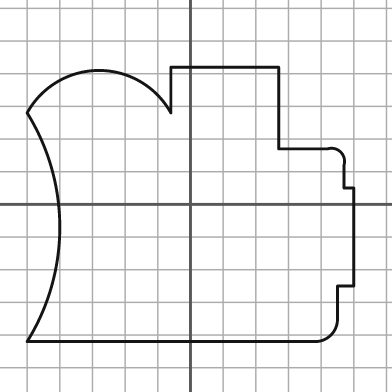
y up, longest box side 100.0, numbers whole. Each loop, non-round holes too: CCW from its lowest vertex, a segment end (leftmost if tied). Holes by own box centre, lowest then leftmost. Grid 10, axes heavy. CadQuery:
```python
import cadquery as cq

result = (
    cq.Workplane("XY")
    .moveTo(-50.0, -42.0)
    .lineTo(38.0, -42.0)
    .threePointArc((43.0, -40.0), (45.0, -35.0))
    .lineTo(45.0, -25.0)
    .lineTo(50.0, -25.0)
    .lineTo(50.0, 5.0)
    .lineTo(47.0, 5.0)
    .lineTo(47.0, 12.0)
    .threePointArc((46.0, 16.0), (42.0, 17.0))
    .lineTo(27.0, 17.0)
    .lineTo(27.0, 42.0)
    .lineTo(-6.0, 42.0)
    .lineTo(-6.0, 28.0)
    .threePointArc((-28.0, 41.0), (-50.0, 28.0))
    .threePointArc((-40.0, -7.0), (-50.0, -42.0))
    .close()
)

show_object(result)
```